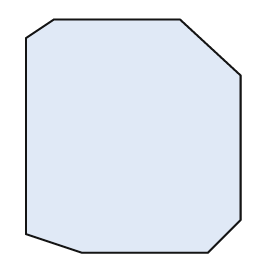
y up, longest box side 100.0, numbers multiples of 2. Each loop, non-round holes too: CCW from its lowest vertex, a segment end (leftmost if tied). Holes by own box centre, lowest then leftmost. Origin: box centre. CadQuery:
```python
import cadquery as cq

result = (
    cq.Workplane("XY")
    .moveTo(-22.0, -50.0)
    .lineTo(32.0, -50.0)
    .lineTo(46.0, -36.0)
    .lineTo(46.0, 26.0)
    .lineTo(20.0, 50.0)
    .lineTo(-34.0, 50.0)
    .lineTo(-46.0, 42.0)
    .lineTo(-46.0, -42.0)
    .close()
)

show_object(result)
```